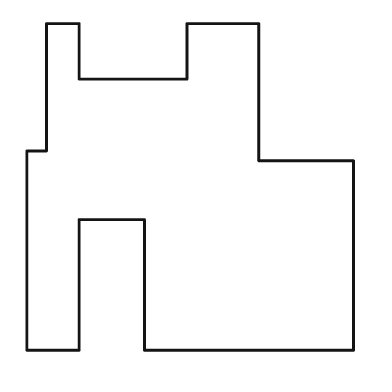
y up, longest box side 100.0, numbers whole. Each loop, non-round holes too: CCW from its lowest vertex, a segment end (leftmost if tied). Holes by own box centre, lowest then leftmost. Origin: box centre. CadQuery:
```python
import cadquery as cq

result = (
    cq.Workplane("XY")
    .moveTo(-50.0, -50.0)
    .lineTo(-34.0, -50.0)
    .lineTo(-34.0, -10.0)
    .lineTo(-14.0, -10.0)
    .lineTo(-14.0, -50.0)
    .lineTo(50.0, -50.0)
    .lineTo(50.0, 8.0)
    .lineTo(21.0, 8.0)
    .lineTo(21.0, 50.0)
    .lineTo(-1.0, 50.0)
    .lineTo(-1.0, 33.0)
    .lineTo(-34.0, 33.0)
    .lineTo(-34.0, 50.0)
    .lineTo(-44.0, 50.0)
    .lineTo(-44.0, 11.0)
    .lineTo(-50.0, 11.0)
    .close()
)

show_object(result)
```